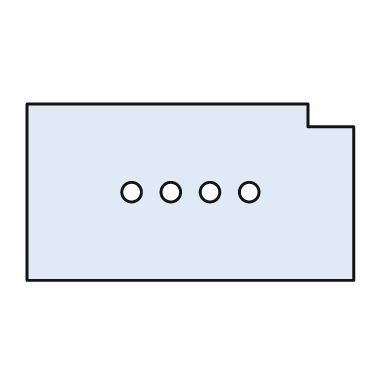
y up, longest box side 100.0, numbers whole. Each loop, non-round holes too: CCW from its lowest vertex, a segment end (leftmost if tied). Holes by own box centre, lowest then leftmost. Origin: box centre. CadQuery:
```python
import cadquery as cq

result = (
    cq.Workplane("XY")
    .moveTo(-50.0, -27.0)
    .lineTo(50.0, -27.0)
    .lineTo(50.0, 20.0)
    .lineTo(36.0, 20.0)
    .lineTo(36.0, 27.0)
    .lineTo(-50.0, 27.0)
    .close()
    .moveTo(-18.0, 0.0)
    .circle(3.0)
    .moveTo(-6.0, 0.0)
    .circle(3.0)
    .moveTo(6.0, 0.0)
    .circle(3.0)
    .moveTo(18.0, 0.0)
    .circle(3.0)
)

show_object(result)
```